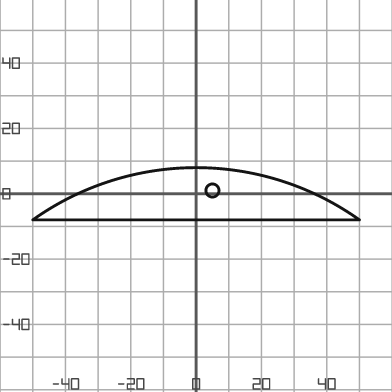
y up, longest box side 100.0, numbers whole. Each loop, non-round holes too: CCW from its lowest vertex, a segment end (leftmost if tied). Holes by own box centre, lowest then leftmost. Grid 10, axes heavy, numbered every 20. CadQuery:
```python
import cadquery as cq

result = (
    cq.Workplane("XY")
    .moveTo(-50.0, -8.0)
    .lineTo(50.0, -8.0)
    .threePointArc((0.0, 8.0), (-50.0, -8.0))
    .close()
    .moveTo(5.0, 1.0)
    .circle(2.0)
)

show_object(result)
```